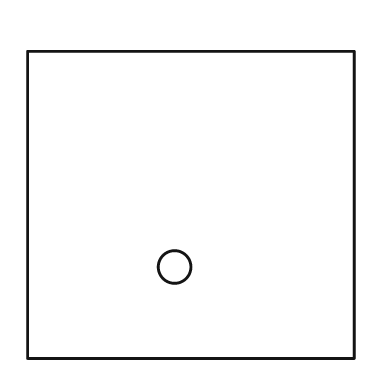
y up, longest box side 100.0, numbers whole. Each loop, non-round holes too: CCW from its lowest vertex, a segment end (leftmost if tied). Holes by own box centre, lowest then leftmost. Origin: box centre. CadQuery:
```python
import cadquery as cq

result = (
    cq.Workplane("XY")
    .moveTo(-50.0, -47.0)
    .lineTo(50.0, -47.0)
    .lineTo(50.0, 47.0)
    .lineTo(-50.0, 47.0)
    .close()
    .moveTo(-5.0, -19.0)
    .circle(5.0)
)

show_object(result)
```